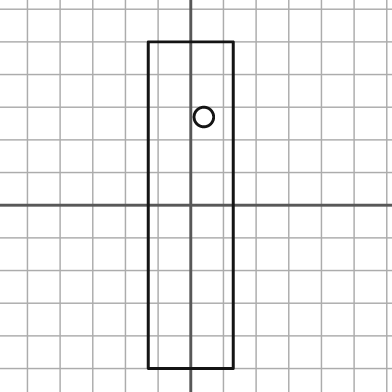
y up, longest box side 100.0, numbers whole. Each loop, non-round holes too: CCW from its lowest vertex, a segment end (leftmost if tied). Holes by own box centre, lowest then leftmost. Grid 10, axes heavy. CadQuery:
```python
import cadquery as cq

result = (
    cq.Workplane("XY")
    .moveTo(-13.0, -50.0)
    .lineTo(13.0, -50.0)
    .lineTo(13.0, 50.0)
    .lineTo(-13.0, 50.0)
    .close()
    .moveTo(4.0, 27.0)
    .circle(3.0)
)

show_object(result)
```